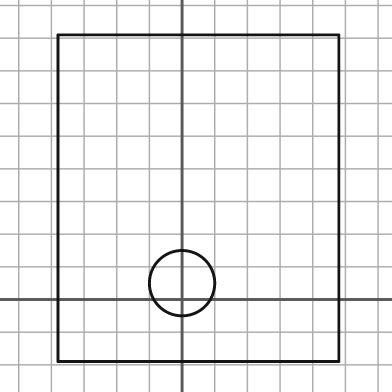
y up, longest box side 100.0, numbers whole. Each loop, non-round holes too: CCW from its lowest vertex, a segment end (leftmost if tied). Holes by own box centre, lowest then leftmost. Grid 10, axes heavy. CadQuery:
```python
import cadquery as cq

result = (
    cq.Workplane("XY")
    .moveTo(-38.0, -19.0)
    .lineTo(48.0, -19.0)
    .lineTo(48.0, 81.0)
    .lineTo(-38.0, 81.0)
    .close()
    .moveTo(0.0, 5.0)
    .circle(10.0)
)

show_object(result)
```